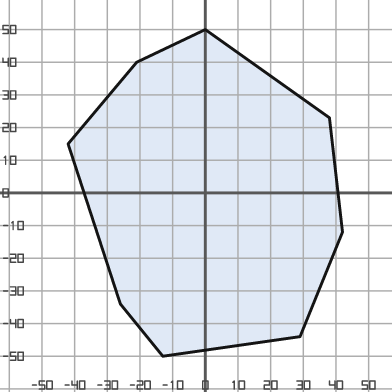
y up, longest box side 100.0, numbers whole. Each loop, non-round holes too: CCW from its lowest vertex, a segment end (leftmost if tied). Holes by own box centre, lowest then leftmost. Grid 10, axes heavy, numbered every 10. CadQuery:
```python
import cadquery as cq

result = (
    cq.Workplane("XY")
    .moveTo(-13.0, -50.0)
    .lineTo(29.0, -44.0)
    .lineTo(42.0, -12.0)
    .lineTo(38.0, 23.0)
    .lineTo(0.0, 50.0)
    .lineTo(-21.0, 40.0)
    .lineTo(-42.0, 15.0)
    .lineTo(-26.0, -34.0)
    .close()
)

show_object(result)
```